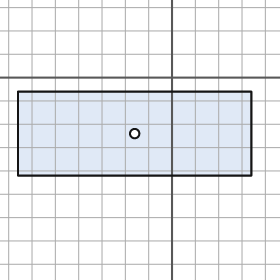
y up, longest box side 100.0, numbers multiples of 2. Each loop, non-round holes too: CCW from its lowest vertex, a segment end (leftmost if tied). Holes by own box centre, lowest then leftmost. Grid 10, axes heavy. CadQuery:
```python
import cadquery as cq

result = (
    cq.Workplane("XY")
    .moveTo(-66.0, -42.0)
    .lineTo(34.0, -42.0)
    .lineTo(34.0, -6.0)
    .lineTo(-66.0, -6.0)
    .close()
    .moveTo(-16.0, -24.0)
    .circle(2.0)
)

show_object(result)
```